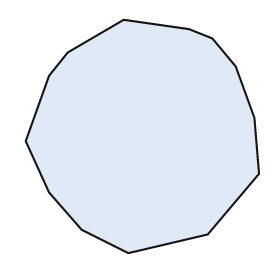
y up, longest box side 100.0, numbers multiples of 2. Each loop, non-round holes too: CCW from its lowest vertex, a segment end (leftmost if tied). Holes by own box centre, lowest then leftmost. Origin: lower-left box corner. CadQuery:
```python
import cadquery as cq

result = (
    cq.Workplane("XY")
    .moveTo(44.0, 0.0)
    .lineTo(78.0, 8.0)
    .lineTo(100.0, 34.0)
    .lineTo(98.0, 58.0)
    .lineTo(90.0, 80.0)
    .lineTo(80.0, 92.0)
    .lineTo(70.0, 96.0)
    .lineTo(42.0, 100.0)
    .lineTo(18.0, 86.0)
    .lineTo(10.0, 76.0)
    .lineTo(0.0, 48.0)
    .lineTo(10.0, 26.0)
    .lineTo(24.0, 10.0)
    .close()
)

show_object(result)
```